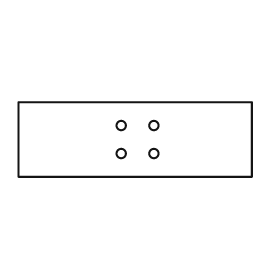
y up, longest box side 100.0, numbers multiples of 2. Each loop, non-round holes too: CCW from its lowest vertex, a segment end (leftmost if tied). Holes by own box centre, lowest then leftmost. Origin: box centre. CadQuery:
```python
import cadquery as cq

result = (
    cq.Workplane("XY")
    .moveTo(-50.0, -16.0)
    .lineTo(50.0, -16.0)
    .lineTo(50.0, 16.0)
    .lineTo(-50.0, 16.0)
    .close()
    .moveTo(-6.0, -6.0)
    .circle(2.0)
    .moveTo(8.0, -6.0)
    .circle(2.0)
    .moveTo(-6.0, 6.0)
    .circle(2.0)
    .moveTo(8.0, 6.0)
    .circle(2.0)
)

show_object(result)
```